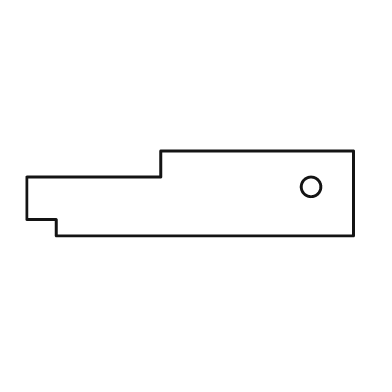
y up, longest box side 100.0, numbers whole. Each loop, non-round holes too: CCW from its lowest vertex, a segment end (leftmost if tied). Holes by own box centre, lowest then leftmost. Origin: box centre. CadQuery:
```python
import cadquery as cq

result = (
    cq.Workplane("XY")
    .moveTo(-41.0, -13.0)
    .lineTo(50.0, -13.0)
    .lineTo(50.0, 13.0)
    .lineTo(-9.0, 13.0)
    .lineTo(-9.0, 5.0)
    .lineTo(-50.0, 5.0)
    .lineTo(-50.0, -8.0)
    .lineTo(-41.0, -8.0)
    .close()
    .moveTo(37.0, 2.0)
    .circle(3.0)
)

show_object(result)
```